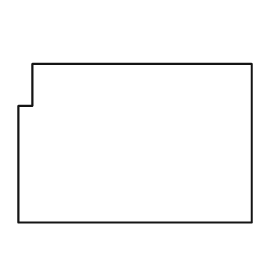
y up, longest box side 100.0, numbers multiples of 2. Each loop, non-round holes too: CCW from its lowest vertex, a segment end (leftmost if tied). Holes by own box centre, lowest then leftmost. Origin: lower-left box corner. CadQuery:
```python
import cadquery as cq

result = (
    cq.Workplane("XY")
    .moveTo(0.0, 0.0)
    .lineTo(100.0, 0.0)
    .lineTo(100.0, 68.0)
    .lineTo(6.0, 68.0)
    .lineTo(6.0, 50.0)
    .lineTo(0.0, 50.0)
    .close()
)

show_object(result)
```